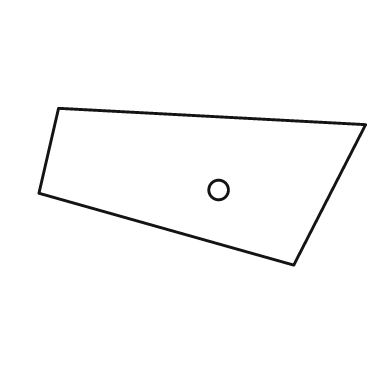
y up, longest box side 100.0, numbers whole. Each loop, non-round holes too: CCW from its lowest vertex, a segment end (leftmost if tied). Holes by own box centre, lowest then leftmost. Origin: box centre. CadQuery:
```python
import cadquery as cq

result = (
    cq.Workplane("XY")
    .moveTo(28.0, -24.0)
    .lineTo(50.0, 19.0)
    .lineTo(-44.0, 24.0)
    .lineTo(-50.0, -2.0)
    .close()
    .moveTo(5.0, -1.0)
    .circle(3.0)
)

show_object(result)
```